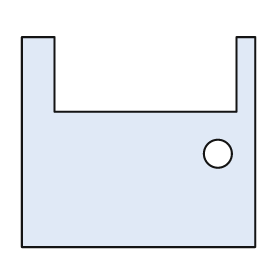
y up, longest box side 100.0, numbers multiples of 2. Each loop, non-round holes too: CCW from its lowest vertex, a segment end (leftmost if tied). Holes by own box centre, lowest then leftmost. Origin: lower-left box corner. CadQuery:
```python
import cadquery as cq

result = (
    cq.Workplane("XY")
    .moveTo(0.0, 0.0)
    .lineTo(100.0, 0.0)
    .lineTo(100.0, 90.0)
    .lineTo(92.0, 90.0)
    .lineTo(92.0, 58.0)
    .lineTo(14.0, 58.0)
    .lineTo(14.0, 90.0)
    .lineTo(0.0, 90.0)
    .close()
    .moveTo(84.0, 40.0)
    .circle(6.0)
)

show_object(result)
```